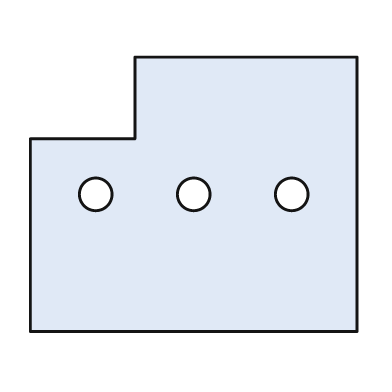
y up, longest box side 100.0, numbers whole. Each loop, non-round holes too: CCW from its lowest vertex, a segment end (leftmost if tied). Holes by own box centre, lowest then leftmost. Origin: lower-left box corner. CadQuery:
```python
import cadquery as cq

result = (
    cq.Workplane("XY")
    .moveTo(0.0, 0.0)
    .lineTo(100.0, 0.0)
    .lineTo(100.0, 84.0)
    .lineTo(32.0, 84.0)
    .lineTo(32.0, 59.0)
    .lineTo(0.0, 59.0)
    .close()
    .moveTo(20.0, 42.0)
    .circle(5.0)
    .moveTo(50.0, 42.0)
    .circle(5.0)
    .moveTo(80.0, 42.0)
    .circle(5.0)
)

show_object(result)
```